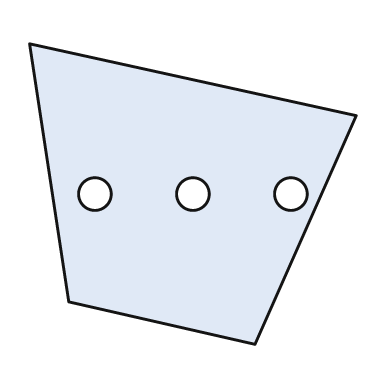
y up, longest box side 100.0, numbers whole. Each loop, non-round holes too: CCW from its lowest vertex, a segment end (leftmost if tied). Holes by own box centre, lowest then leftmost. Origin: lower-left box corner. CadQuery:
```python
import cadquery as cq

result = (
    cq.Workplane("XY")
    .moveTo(69.0, 0.0)
    .lineTo(100.0, 70.0)
    .lineTo(0.0, 92.0)
    .lineTo(12.0, 13.0)
    .close()
    .moveTo(20.0, 46.0)
    .circle(5.0)
    .moveTo(50.0, 46.0)
    .circle(5.0)
    .moveTo(80.0, 46.0)
    .circle(5.0)
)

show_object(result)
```